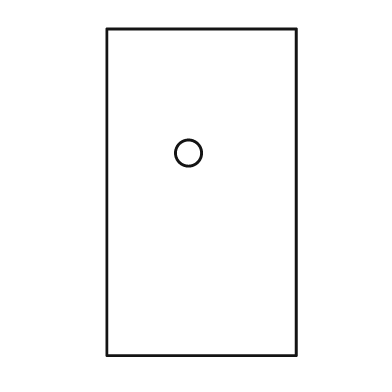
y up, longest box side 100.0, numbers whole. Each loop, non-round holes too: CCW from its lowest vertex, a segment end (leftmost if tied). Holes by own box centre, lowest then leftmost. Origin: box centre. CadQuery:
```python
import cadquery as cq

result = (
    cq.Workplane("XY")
    .moveTo(-29.0, -50.0)
    .lineTo(29.0, -50.0)
    .lineTo(29.0, 50.0)
    .lineTo(-29.0, 50.0)
    .close()
    .moveTo(-4.0, 12.0)
    .circle(4.0)
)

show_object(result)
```